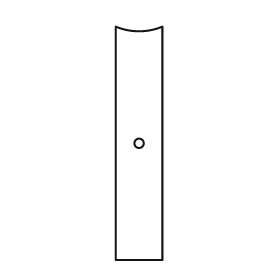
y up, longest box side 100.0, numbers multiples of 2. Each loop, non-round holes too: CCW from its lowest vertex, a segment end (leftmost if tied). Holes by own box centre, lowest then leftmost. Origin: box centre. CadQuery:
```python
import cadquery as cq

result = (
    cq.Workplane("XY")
    .moveTo(-10.0, -50.0)
    .lineTo(10.0, -50.0)
    .lineTo(10.0, 50.0)
    .threePointArc((0.0, 48.0), (-10.0, 50.0))
    .close()
    .moveTo(0.0, 0.0)
    .circle(2.0)
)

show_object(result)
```